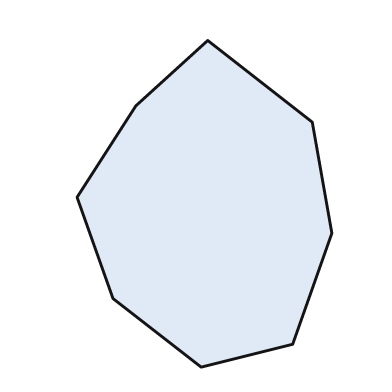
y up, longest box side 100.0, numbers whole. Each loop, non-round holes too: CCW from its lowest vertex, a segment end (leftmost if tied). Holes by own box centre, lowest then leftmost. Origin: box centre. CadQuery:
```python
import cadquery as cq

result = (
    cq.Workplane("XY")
    .moveTo(-1.0, -50.0)
    .lineTo(27.0, -43.0)
    .lineTo(39.0, -9.0)
    .lineTo(33.0, 25.0)
    .lineTo(1.0, 50.0)
    .lineTo(-21.0, 30.0)
    .lineTo(-39.0, 2.0)
    .lineTo(-28.0, -29.0)
    .close()
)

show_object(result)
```